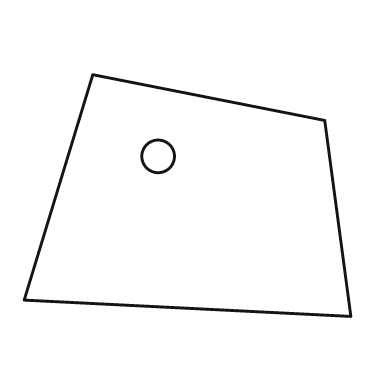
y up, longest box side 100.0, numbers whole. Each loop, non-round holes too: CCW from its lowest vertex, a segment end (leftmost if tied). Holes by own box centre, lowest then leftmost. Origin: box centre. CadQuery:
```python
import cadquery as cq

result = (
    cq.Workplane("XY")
    .moveTo(50.0, -37.0)
    .lineTo(42.0, 23.0)
    .lineTo(-29.0, 37.0)
    .lineTo(-50.0, -32.0)
    .close()
    .moveTo(-9.0, 12.0)
    .circle(5.0)
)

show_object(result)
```